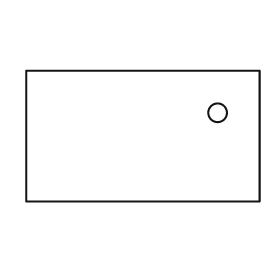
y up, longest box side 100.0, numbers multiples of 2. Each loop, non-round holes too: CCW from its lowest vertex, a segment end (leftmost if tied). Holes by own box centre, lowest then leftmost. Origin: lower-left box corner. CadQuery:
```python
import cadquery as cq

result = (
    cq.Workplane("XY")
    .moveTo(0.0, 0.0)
    .lineTo(100.0, 0.0)
    .lineTo(100.0, 56.0)
    .lineTo(0.0, 56.0)
    .close()
    .moveTo(82.0, 38.0)
    .circle(4.0)
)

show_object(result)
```